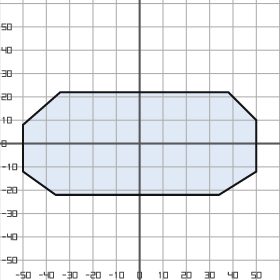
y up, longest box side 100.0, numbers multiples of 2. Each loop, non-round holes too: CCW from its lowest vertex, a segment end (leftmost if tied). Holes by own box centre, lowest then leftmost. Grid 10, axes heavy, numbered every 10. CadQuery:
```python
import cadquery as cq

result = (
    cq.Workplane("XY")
    .moveTo(-36.0, -22.0)
    .lineTo(34.0, -22.0)
    .lineTo(50.0, -12.0)
    .lineTo(50.0, 10.0)
    .lineTo(38.0, 22.0)
    .lineTo(-34.0, 22.0)
    .lineTo(-50.0, 8.0)
    .lineTo(-50.0, -12.0)
    .close()
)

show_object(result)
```